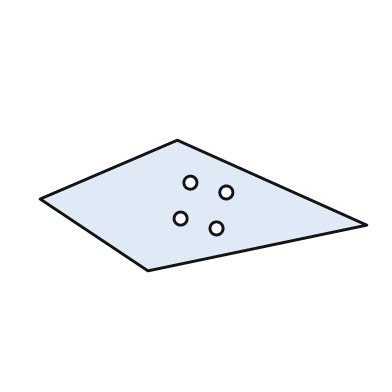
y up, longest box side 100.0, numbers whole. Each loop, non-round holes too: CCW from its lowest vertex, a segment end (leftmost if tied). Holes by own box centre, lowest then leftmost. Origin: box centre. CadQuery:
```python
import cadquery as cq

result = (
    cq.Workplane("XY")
    .moveTo(-17.0, -20.0)
    .lineTo(50.0, -6.0)
    .lineTo(-8.0, 20.0)
    .lineTo(-50.0, 2.0)
    .close()
    .moveTo(4.0, -7.0)
    .circle(2.0)
    .moveTo(-7.0, -4.0)
    .circle(2.0)
    .moveTo(7.0, 4.0)
    .circle(2.0)
    .moveTo(-4.0, 7.0)
    .circle(2.0)
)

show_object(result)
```